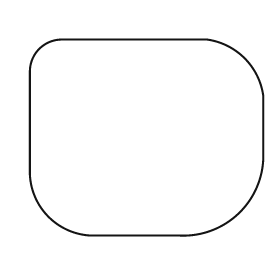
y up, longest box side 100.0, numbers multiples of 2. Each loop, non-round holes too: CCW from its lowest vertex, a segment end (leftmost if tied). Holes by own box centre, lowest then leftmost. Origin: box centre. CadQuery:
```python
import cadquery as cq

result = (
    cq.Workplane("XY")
    .moveTo(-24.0, -42.0)
    .lineTo(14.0, -42.0)
    .threePointArc((40.0, -32.0), (50.0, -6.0))
    .lineTo(50.0, 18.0)
    .threePointArc((42.0, 34.0), (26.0, 42.0))
    .lineTo(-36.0, 42.0)
    .threePointArc((-46.0, 38.0), (-50.0, 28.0))
    .lineTo(-50.0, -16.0)
    .threePointArc((-42.0, -34.0), (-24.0, -42.0))
    .close()
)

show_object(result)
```